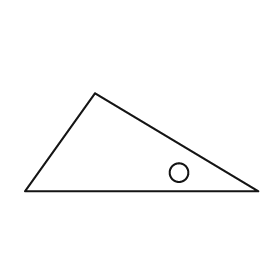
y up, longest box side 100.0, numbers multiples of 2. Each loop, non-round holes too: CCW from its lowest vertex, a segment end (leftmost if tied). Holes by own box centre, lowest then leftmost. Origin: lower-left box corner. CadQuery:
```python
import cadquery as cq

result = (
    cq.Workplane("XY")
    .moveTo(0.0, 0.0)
    .lineTo(100.0, 0.0)
    .lineTo(30.0, 42.0)
    .close()
    .moveTo(66.0, 8.0)
    .circle(4.0)
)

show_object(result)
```